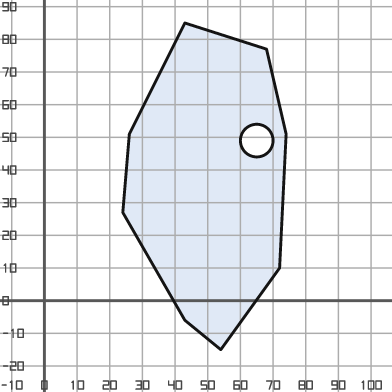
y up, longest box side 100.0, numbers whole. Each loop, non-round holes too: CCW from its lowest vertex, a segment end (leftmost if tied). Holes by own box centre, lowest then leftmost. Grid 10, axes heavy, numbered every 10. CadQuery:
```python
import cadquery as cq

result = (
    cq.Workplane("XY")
    .moveTo(54.0, -15.0)
    .lineTo(72.0, 10.0)
    .lineTo(74.0, 51.0)
    .lineTo(68.0, 77.0)
    .lineTo(43.0, 85.0)
    .lineTo(26.0, 51.0)
    .lineTo(24.0, 27.0)
    .lineTo(43.0, -6.0)
    .close()
    .moveTo(65.0, 49.0)
    .circle(5.0)
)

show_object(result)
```